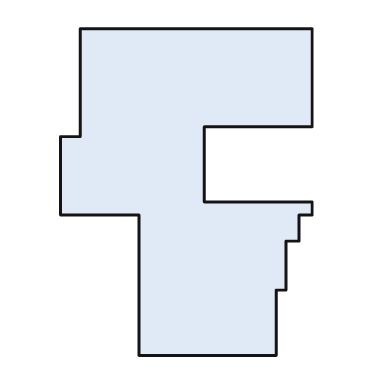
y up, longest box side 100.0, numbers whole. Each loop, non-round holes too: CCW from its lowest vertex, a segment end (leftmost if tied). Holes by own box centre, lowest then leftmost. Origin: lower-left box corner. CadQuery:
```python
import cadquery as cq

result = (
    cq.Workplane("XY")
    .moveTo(24.0, 0.0)
    .lineTo(66.0, 0.0)
    .lineTo(66.0, 20.0)
    .lineTo(69.0, 20.0)
    .lineTo(69.0, 35.0)
    .lineTo(73.0, 35.0)
    .lineTo(73.0, 43.0)
    .lineTo(77.0, 43.0)
    .lineTo(77.0, 47.0)
    .lineTo(44.0, 47.0)
    .lineTo(44.0, 70.0)
    .lineTo(77.0, 70.0)
    .lineTo(77.0, 100.0)
    .lineTo(6.0, 100.0)
    .lineTo(6.0, 67.0)
    .lineTo(0.0, 67.0)
    .lineTo(0.0, 43.0)
    .lineTo(24.0, 43.0)
    .close()
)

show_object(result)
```